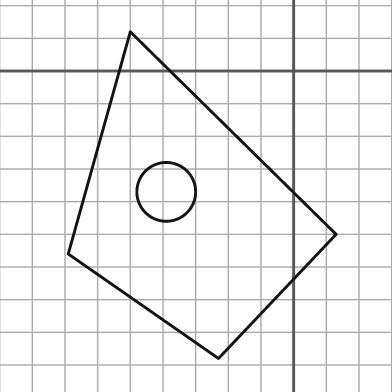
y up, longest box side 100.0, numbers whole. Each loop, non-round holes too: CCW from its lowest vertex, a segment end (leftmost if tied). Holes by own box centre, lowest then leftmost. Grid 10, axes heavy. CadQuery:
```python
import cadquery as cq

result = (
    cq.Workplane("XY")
    .moveTo(-23.0, -88.0)
    .lineTo(13.0, -50.0)
    .lineTo(-50.0, 12.0)
    .lineTo(-69.0, -56.0)
    .close()
    .moveTo(-39.0, -37.0)
    .circle(9.0)
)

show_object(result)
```